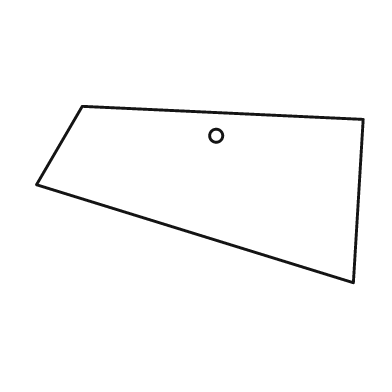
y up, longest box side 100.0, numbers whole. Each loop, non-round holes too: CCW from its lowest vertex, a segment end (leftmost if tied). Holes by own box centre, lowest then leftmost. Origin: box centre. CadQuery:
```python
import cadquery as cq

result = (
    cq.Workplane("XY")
    .moveTo(47.0, -27.0)
    .lineTo(50.0, 23.0)
    .lineTo(-36.0, 27.0)
    .lineTo(-50.0, 3.0)
    .close()
    .moveTo(5.0, 18.0)
    .circle(2.0)
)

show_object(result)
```